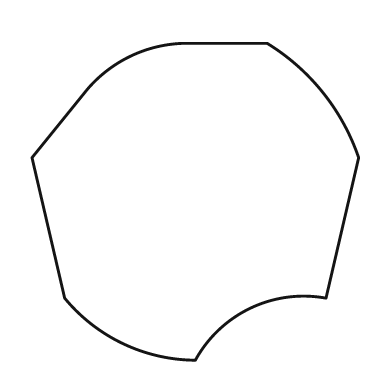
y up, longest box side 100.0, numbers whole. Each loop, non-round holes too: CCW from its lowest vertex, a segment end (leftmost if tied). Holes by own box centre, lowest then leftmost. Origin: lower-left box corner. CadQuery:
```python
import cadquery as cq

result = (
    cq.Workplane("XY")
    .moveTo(50.0, 0.0)
    .threePointArc((67.0, 16.0), (90.0, 19.0))
    .lineTo(100.0, 62.0)
    .threePointArc((89.0, 82.0), (72.0, 97.0))
    .lineTo(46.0, 97.0)
    .threePointArc((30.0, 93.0), (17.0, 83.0))
    .lineTo(0.0, 62.0)
    .lineTo(10.0, 19.0)
    .threePointArc((28.0, 5.0), (50.0, 0.0))
    .close()
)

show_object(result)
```